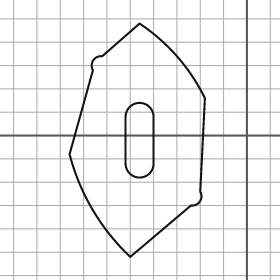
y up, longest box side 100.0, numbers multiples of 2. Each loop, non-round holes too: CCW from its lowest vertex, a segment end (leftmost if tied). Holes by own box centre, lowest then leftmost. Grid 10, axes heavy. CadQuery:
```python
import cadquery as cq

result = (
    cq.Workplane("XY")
    .moveTo(-50.0, -52.0)
    .lineTo(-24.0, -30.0)
    .threePointArc((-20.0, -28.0), (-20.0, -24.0))
    .lineTo(-18.0, 16.0)
    .threePointArc((-30.0, 34.0), (-46.0, 48.0))
    .lineTo(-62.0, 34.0)
    .threePointArc((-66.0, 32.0), (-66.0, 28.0))
    .lineTo(-76.0, -8.0)
    .threePointArc((-66.0, -32.0), (-50.0, -52.0))
    .close()
    .moveTo(-52.0, -12.0)
    .threePointArc((-46.0, -18.0), (-40.0, -12.0))
    .lineTo(-40.0, 8.0)
    .threePointArc((-46.0, 14.0), (-52.0, 8.0))
    .close()
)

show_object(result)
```